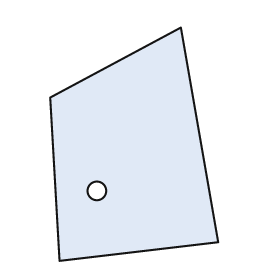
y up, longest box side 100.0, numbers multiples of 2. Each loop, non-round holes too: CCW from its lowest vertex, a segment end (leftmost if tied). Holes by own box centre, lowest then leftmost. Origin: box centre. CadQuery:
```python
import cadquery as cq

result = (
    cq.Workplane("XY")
    .moveTo(-32.0, -50.0)
    .lineTo(36.0, -42.0)
    .lineTo(20.0, 50.0)
    .lineTo(-36.0, 20.0)
    .close()
    .moveTo(-16.0, -20.0)
    .circle(4.0)
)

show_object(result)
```